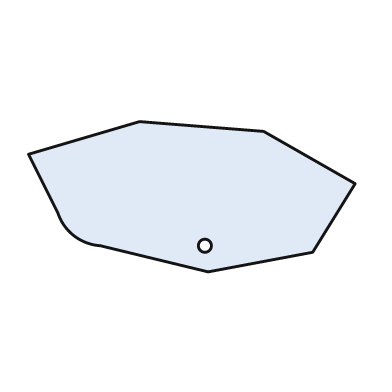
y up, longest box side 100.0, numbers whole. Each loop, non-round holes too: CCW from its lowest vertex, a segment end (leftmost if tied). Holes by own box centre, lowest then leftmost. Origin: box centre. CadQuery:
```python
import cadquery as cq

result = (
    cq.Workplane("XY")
    .moveTo(5.0, -23.0)
    .lineTo(37.0, -17.0)
    .lineTo(50.0, 4.0)
    .lineTo(22.0, 20.0)
    .lineTo(-16.0, 23.0)
    .lineTo(-50.0, 13.0)
    .lineTo(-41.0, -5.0)
    .threePointArc((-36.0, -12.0), (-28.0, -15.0))
    .close()
    .moveTo(4.0, -15.0)
    .circle(2.0)
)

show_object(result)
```